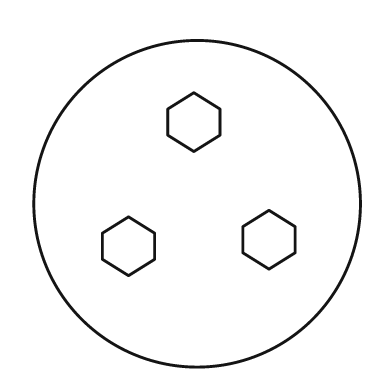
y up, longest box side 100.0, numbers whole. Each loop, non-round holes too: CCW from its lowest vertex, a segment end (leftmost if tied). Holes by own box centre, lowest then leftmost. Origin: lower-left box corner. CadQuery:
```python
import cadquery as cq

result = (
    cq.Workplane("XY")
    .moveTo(50.0, 50.0)
    .circle(50.0)
    .moveTo(29.0, 28.0)
    .lineTo(37.0, 33.0)
    .lineTo(37.0, 41.0)
    .lineTo(29.0, 46.0)
    .lineTo(21.0, 41.0)
    .lineTo(21.0, 33.0)
    .close()
    .moveTo(72.0, 30.0)
    .lineTo(80.0, 35.0)
    .lineTo(80.0, 43.0)
    .lineTo(72.0, 48.0)
    .lineTo(64.0, 43.0)
    .lineTo(64.0, 35.0)
    .close()
    .moveTo(49.0, 66.0)
    .lineTo(57.0, 71.0)
    .lineTo(57.0, 79.0)
    .lineTo(49.0, 84.0)
    .lineTo(41.0, 79.0)
    .lineTo(41.0, 71.0)
    .close()
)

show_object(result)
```